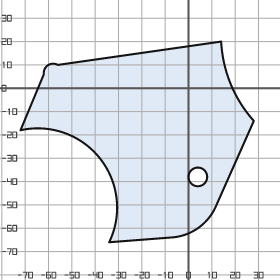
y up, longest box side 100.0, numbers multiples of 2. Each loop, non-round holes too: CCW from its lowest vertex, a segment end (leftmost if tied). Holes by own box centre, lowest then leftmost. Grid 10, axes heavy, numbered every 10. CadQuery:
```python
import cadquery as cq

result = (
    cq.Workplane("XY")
    .moveTo(-34.0, -66.0)
    .lineTo(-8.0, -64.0)
    .threePointArc((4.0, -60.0), (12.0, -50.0))
    .lineTo(28.0, -14.0)
    .threePointArc((18.0, 2.0), (14.0, 20.0))
    .lineTo(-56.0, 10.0)
    .threePointArc((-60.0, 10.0), (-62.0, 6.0))
    .lineTo(-72.0, -18.0)
    .threePointArc((-38.0, -30.0), (-34.0, -66.0))
    .close()
    .moveTo(4.0, -38.0)
    .circle(4.0)
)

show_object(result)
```